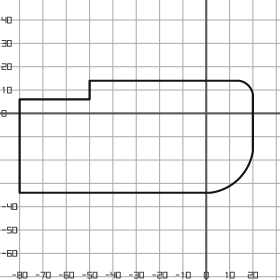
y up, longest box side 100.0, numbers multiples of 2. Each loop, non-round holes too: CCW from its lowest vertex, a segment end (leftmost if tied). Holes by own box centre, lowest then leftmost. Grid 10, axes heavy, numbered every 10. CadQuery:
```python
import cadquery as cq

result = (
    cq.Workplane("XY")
    .moveTo(-80.0, -34.0)
    .lineTo(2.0, -34.0)
    .threePointArc((14.0, -28.0), (20.0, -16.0))
    .lineTo(20.0, 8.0)
    .threePointArc((18.0, 12.0), (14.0, 14.0))
    .lineTo(-50.0, 14.0)
    .lineTo(-50.0, 6.0)
    .lineTo(-80.0, 6.0)
    .close()
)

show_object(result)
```